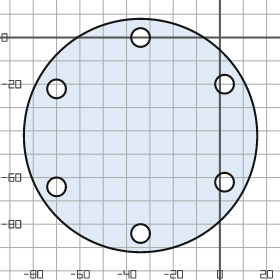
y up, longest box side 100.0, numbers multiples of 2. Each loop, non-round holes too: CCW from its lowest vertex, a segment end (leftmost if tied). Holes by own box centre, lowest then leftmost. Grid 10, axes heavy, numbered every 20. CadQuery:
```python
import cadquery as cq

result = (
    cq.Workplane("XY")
    .moveTo(-34.0, -42.0)
    .circle(50.0)
    .moveTo(-34.0, -84.0)
    .circle(4.0)
    .moveTo(-70.0, -64.0)
    .circle(4.0)
    .moveTo(2.0, -62.0)
    .circle(4.0)
    .moveTo(-70.0, -22.0)
    .circle(4.0)
    .moveTo(2.0, -20.0)
    .circle(4.0)
    .moveTo(-34.0, 0.0)
    .circle(4.0)
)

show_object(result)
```